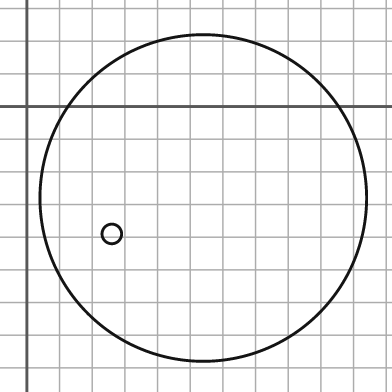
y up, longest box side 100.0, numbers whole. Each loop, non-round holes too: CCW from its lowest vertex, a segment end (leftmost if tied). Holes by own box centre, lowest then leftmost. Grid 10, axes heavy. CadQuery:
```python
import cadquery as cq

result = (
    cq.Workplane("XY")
    .moveTo(54.0, -28.0)
    .circle(50.0)
    .moveTo(26.0, -39.0)
    .circle(3.0)
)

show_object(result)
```